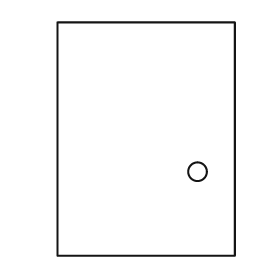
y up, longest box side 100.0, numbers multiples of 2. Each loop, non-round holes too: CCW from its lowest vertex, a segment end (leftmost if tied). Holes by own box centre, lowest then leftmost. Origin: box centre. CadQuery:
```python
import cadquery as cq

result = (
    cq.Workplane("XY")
    .moveTo(-38.0, -50.0)
    .lineTo(38.0, -50.0)
    .lineTo(38.0, 50.0)
    .lineTo(-38.0, 50.0)
    .close()
    .moveTo(22.0, -14.0)
    .circle(4.0)
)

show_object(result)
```